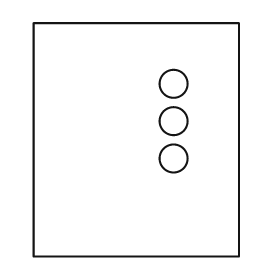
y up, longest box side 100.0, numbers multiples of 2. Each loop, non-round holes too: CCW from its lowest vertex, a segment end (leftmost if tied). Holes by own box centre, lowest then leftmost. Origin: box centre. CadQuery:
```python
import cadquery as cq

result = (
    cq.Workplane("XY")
    .moveTo(-44.0, -50.0)
    .lineTo(44.0, -50.0)
    .lineTo(44.0, 50.0)
    .lineTo(-44.0, 50.0)
    .close()
    .moveTo(16.0, -8.0)
    .circle(6.0)
    .moveTo(16.0, 8.0)
    .circle(6.0)
    .moveTo(16.0, 24.0)
    .circle(6.0)
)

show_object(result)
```